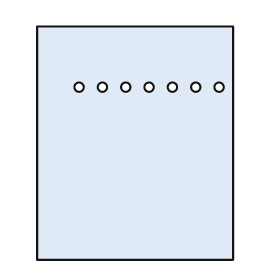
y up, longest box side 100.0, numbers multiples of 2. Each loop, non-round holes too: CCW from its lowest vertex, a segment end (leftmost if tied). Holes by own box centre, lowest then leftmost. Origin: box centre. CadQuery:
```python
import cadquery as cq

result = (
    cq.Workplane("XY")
    .moveTo(-42.0, -50.0)
    .lineTo(42.0, -50.0)
    .lineTo(42.0, 50.0)
    .lineTo(-42.0, 50.0)
    .close()
    .moveTo(-24.0, 24.0)
    .circle(2.0)
    .moveTo(-14.0, 24.0)
    .circle(2.0)
    .moveTo(-4.0, 24.0)
    .circle(2.0)
    .moveTo(6.0, 24.0)
    .circle(2.0)
    .moveTo(16.0, 24.0)
    .circle(2.0)
    .moveTo(26.0, 24.0)
    .circle(2.0)
    .moveTo(36.0, 24.0)
    .circle(2.0)
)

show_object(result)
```